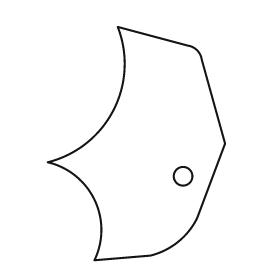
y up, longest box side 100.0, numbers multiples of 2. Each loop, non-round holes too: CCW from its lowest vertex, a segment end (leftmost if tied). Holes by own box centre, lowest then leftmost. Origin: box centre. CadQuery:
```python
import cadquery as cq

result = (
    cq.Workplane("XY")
    .moveTo(-18.0, -50.0)
    .lineTo(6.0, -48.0)
    .threePointArc((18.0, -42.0), (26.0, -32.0))
    .lineTo(38.0, 0.0)
    .lineTo(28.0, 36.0)
    .threePointArc((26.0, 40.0), (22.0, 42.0))
    .lineTo(-8.0, 50.0)
    .threePointArc((-10.0, 14.0), (-38.0, -8.0))
    .threePointArc((-18.0, -24.0), (-18.0, -50.0))
    .close()
    .moveTo(20.0, -14.0)
    .circle(4.0)
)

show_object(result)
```